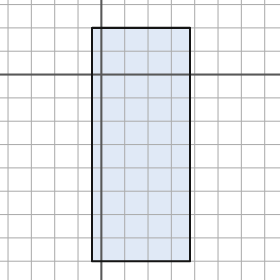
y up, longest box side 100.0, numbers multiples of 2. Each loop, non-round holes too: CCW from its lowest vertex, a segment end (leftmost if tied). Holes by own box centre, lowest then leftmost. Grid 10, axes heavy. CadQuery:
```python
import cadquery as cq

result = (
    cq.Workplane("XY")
    .moveTo(-4.0, -80.0)
    .lineTo(38.0, -80.0)
    .lineTo(38.0, 20.0)
    .lineTo(-4.0, 20.0)
    .close()
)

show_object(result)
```